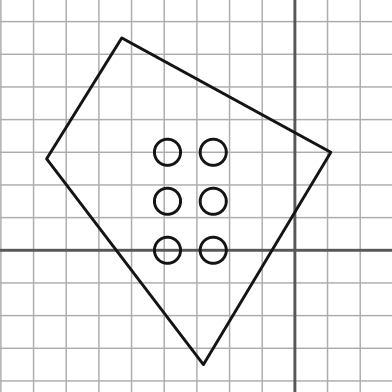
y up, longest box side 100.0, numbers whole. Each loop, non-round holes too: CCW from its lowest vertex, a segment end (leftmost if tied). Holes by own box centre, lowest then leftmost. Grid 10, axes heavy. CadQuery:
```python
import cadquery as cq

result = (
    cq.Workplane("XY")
    .moveTo(-28.0, -35.0)
    .lineTo(11.0, 30.0)
    .lineTo(-53.0, 65.0)
    .lineTo(-76.0, 28.0)
    .close()
    .moveTo(-39.0, 0.0)
    .circle(4.0)
    .moveTo(-25.0, 0.0)
    .circle(4.0)
    .moveTo(-39.0, 15.0)
    .circle(4.0)
    .moveTo(-25.0, 15.0)
    .circle(4.0)
    .moveTo(-39.0, 30.0)
    .circle(4.0)
    .moveTo(-25.0, 30.0)
    .circle(4.0)
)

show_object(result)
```